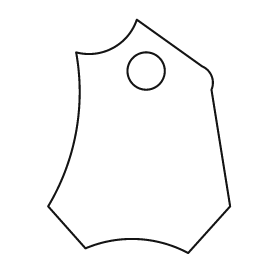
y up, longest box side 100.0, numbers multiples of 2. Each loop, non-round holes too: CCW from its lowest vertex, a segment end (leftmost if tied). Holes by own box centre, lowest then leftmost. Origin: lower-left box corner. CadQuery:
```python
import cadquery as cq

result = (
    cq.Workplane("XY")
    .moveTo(60.0, 0.0)
    .lineTo(78.0, 20.0)
    .lineTo(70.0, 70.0)
    .threePointArc((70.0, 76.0), (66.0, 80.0))
    .lineTo(38.0, 100.0)
    .threePointArc((28.0, 88.0), (12.0, 86.0))
    .threePointArc((12.0, 52.0), (0.0, 20.0))
    .lineTo(16.0, 2.0)
    .threePointArc((38.0, 6.0), (60.0, 0.0))
    .close()
    .moveTo(42.0, 78.0)
    .circle(8.0)
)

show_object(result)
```